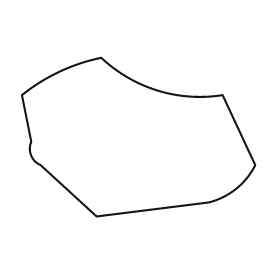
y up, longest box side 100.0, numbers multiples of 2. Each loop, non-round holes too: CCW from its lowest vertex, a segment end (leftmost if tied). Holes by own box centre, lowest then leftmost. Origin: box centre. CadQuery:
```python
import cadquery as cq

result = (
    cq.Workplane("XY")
    .moveTo(-18.0, -34.0)
    .lineTo(30.0, -28.0)
    .threePointArc((42.0, -22.0), (50.0, -12.0))
    .lineTo(36.0, 18.0)
    .threePointArc((8.0, 20.0), (-16.0, 34.0))
    .threePointArc((-34.0, 28.0), (-50.0, 18.0))
    .lineTo(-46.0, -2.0)
    .threePointArc((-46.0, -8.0), (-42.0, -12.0))
    .close()
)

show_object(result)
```